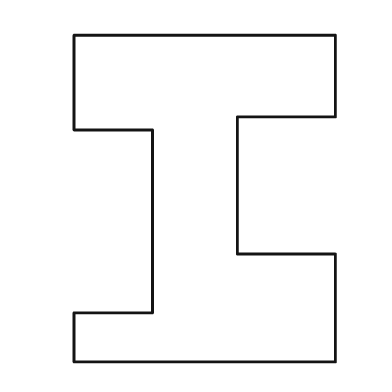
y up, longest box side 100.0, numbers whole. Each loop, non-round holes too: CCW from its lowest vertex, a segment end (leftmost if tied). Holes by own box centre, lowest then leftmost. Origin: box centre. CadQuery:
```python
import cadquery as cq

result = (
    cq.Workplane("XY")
    .moveTo(-40.0, -50.0)
    .lineTo(40.0, -50.0)
    .lineTo(40.0, -17.0)
    .lineTo(10.0, -17.0)
    .lineTo(10.0, 25.0)
    .lineTo(40.0, 25.0)
    .lineTo(40.0, 50.0)
    .lineTo(-40.0, 50.0)
    .lineTo(-40.0, 21.0)
    .lineTo(-16.0, 21.0)
    .lineTo(-16.0, -35.0)
    .lineTo(-40.0, -35.0)
    .close()
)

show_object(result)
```